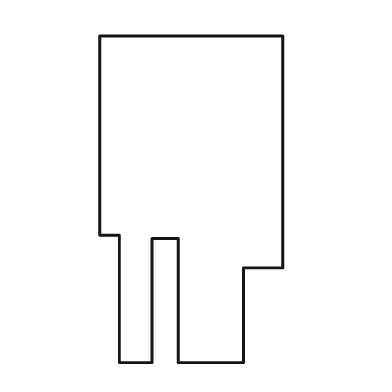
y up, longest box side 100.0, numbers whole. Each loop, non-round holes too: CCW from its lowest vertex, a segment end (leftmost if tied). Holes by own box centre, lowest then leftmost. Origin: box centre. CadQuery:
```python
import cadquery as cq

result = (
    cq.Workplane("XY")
    .moveTo(-22.0, -50.0)
    .lineTo(-12.0, -50.0)
    .lineTo(-12.0, -12.0)
    .lineTo(-4.0, -12.0)
    .lineTo(-4.0, -50.0)
    .lineTo(16.0, -50.0)
    .lineTo(16.0, -21.0)
    .lineTo(28.0, -21.0)
    .lineTo(28.0, 50.0)
    .lineTo(-28.0, 50.0)
    .lineTo(-28.0, -11.0)
    .lineTo(-22.0, -11.0)
    .close()
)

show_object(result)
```